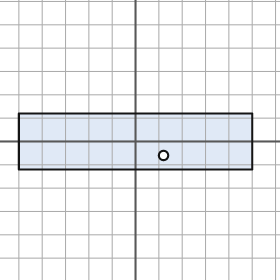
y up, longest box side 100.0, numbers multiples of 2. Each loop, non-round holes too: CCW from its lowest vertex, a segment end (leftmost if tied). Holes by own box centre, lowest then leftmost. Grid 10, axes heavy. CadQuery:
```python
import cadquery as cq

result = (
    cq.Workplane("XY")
    .moveTo(-50.0, -12.0)
    .lineTo(50.0, -12.0)
    .lineTo(50.0, 12.0)
    .lineTo(-50.0, 12.0)
    .close()
    .moveTo(12.0, -6.0)
    .circle(2.0)
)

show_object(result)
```